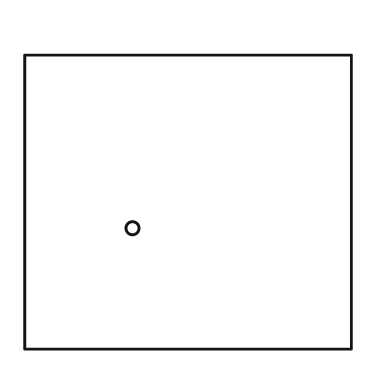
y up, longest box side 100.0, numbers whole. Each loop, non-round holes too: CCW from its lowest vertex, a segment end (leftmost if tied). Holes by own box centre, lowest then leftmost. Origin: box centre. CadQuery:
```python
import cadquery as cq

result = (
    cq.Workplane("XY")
    .moveTo(-50.0, -45.0)
    .lineTo(50.0, -45.0)
    .lineTo(50.0, 45.0)
    .lineTo(-50.0, 45.0)
    .close()
    .moveTo(-17.0, -8.0)
    .circle(2.0)
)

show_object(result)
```